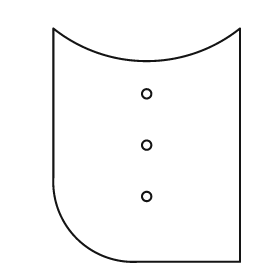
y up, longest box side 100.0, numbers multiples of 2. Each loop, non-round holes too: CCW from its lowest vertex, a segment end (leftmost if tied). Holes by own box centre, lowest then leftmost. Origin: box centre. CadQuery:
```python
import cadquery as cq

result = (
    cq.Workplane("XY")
    .moveTo(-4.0, -50.0)
    .lineTo(40.0, -50.0)
    .lineTo(40.0, 50.0)
    .threePointArc((0.0, 36.0), (-40.0, 50.0))
    .lineTo(-40.0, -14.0)
    .threePointArc((-30.0, -40.0), (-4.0, -50.0))
    .close()
    .moveTo(0.0, -22.0)
    .circle(2.0)
    .moveTo(0.0, 0.0)
    .circle(2.0)
    .moveTo(0.0, 22.0)
    .circle(2.0)
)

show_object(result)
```